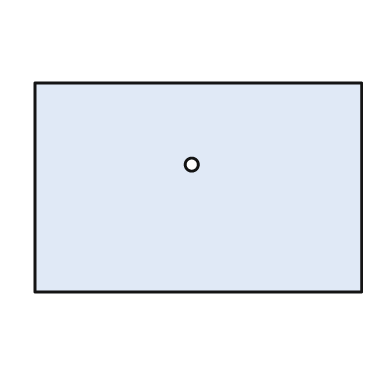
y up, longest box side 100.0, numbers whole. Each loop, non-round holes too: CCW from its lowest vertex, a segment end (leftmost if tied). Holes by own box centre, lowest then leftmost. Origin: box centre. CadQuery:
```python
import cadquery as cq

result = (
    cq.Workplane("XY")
    .moveTo(-50.0, -32.0)
    .lineTo(50.0, -32.0)
    .lineTo(50.0, 32.0)
    .lineTo(-50.0, 32.0)
    .close()
    .moveTo(-2.0, 7.0)
    .circle(2.0)
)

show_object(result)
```